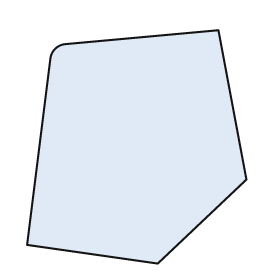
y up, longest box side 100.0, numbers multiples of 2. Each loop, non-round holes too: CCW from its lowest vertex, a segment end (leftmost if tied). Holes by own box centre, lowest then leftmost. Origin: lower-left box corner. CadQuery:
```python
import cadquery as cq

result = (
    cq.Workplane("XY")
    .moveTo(56.0, 0.0)
    .lineTo(94.0, 36.0)
    .lineTo(82.0, 100.0)
    .lineTo(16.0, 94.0)
    .threePointArc((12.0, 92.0), (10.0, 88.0))
    .lineTo(0.0, 8.0)
    .close()
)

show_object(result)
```